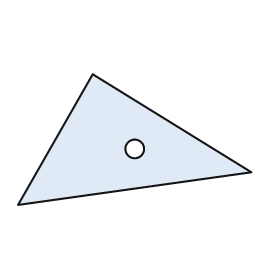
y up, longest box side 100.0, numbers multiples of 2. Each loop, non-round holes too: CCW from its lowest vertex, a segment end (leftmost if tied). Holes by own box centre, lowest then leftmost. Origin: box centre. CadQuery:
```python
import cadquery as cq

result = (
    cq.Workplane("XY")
    .moveTo(-50.0, -28.0)
    .lineTo(50.0, -14.0)
    .lineTo(-18.0, 28.0)
    .close()
    .moveTo(0.0, -4.0)
    .circle(4.0)
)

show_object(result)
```